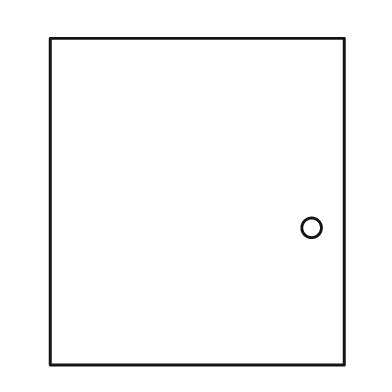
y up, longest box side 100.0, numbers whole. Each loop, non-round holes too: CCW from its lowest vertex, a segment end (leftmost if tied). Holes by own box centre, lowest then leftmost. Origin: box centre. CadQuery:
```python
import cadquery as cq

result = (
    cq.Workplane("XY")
    .moveTo(-45.0, -50.0)
    .lineTo(45.0, -50.0)
    .lineTo(45.0, 50.0)
    .lineTo(-45.0, 50.0)
    .close()
    .moveTo(35.0, -8.0)
    .circle(3.0)
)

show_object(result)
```